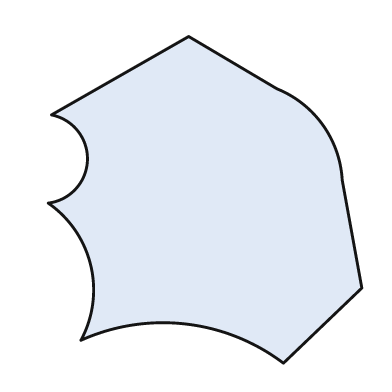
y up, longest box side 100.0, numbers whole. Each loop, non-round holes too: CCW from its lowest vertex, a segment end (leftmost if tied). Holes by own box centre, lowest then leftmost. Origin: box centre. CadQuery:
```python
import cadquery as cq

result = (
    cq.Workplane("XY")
    .moveTo(24.0, -50.0)
    .lineTo(48.0, -27.0)
    .lineTo(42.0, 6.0)
    .threePointArc((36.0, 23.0), (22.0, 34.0))
    .lineTo(-5.0, 50.0)
    .lineTo(-47.0, 26.0)
    .threePointArc((-36.0, 12.0), (-48.0, -1.0))
    .threePointArc((-35.0, -20.0), (-38.0, -43.0))
    .threePointArc((-6.0, -38.0), (24.0, -50.0))
    .close()
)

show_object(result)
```